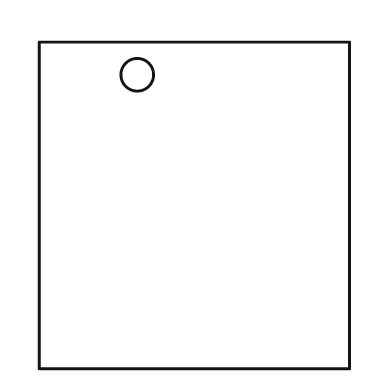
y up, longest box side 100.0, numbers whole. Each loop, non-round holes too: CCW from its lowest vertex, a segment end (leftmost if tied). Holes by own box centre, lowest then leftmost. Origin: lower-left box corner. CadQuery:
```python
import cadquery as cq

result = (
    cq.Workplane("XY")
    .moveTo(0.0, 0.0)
    .lineTo(95.0, 0.0)
    .lineTo(95.0, 100.0)
    .lineTo(0.0, 100.0)
    .close()
    .moveTo(30.0, 90.0)
    .circle(5.0)
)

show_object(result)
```